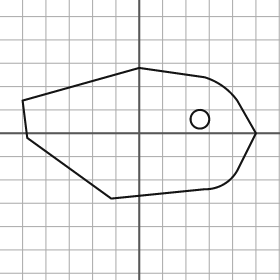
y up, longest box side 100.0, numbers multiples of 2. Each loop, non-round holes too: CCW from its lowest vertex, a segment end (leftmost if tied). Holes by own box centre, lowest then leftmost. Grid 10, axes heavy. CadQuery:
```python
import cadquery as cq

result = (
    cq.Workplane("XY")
    .moveTo(-12.0, -28.0)
    .lineTo(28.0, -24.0)
    .threePointArc((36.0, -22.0), (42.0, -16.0))
    .lineTo(50.0, 0.0)
    .lineTo(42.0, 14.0)
    .threePointArc((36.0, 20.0), (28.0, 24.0))
    .lineTo(0.0, 28.0)
    .lineTo(-50.0, 14.0)
    .lineTo(-48.0, -2.0)
    .close()
    .moveTo(26.0, 6.0)
    .circle(4.0)
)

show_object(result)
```